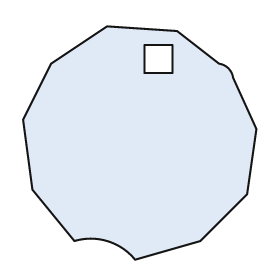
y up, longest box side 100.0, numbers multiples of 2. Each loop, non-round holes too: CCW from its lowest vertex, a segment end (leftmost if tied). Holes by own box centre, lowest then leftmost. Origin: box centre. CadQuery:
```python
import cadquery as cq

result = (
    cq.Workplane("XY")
    .moveTo(-2.0, -50.0)
    .lineTo(26.0, -42.0)
    .lineTo(46.0, -22.0)
    .lineTo(50.0, 6.0)
    .lineTo(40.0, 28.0)
    .threePointArc((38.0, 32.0), (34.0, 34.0))
    .lineTo(16.0, 48.0)
    .lineTo(-14.0, 50.0)
    .lineTo(-38.0, 34.0)
    .lineTo(-50.0, 10.0)
    .lineTo(-46.0, -20.0)
    .lineTo(-28.0, -42.0)
    .threePointArc((-14.0, -42.0), (-2.0, -50.0))
    .close()
    .moveTo(2.0, 30.0)
    .lineTo(14.0, 30.0)
    .lineTo(14.0, 42.0)
    .lineTo(2.0, 42.0)
    .close()
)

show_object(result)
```